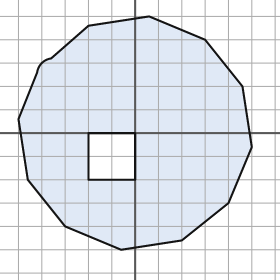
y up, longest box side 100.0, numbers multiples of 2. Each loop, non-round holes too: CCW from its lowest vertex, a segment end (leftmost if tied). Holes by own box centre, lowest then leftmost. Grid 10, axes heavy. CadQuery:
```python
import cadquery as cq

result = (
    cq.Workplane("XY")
    .moveTo(-6.0, -50.0)
    .lineTo(20.0, -46.0)
    .lineTo(40.0, -30.0)
    .lineTo(50.0, -6.0)
    .lineTo(46.0, 20.0)
    .lineTo(30.0, 40.0)
    .lineTo(6.0, 50.0)
    .lineTo(-20.0, 46.0)
    .lineTo(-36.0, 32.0)
    .threePointArc((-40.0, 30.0), (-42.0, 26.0))
    .lineTo(-50.0, 6.0)
    .lineTo(-46.0, -20.0)
    .lineTo(-30.0, -40.0)
    .close()
    .moveTo(-20.0, -20.0)
    .lineTo(0.0, -20.0)
    .lineTo(0.0, 0.0)
    .lineTo(-20.0, 0.0)
    .close()
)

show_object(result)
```